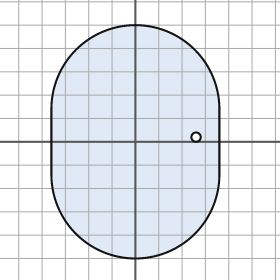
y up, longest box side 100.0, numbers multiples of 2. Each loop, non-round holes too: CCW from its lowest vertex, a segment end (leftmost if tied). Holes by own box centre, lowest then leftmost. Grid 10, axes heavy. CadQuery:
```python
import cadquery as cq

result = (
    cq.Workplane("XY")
    .moveTo(-36.0, -14.0)
    .threePointArc((0.0, -50.0), (36.0, -14.0))
    .lineTo(36.0, 14.0)
    .threePointArc((0.0, 50.0), (-36.0, 14.0))
    .close()
    .moveTo(26.0, 2.0)
    .circle(2.0)
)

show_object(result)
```